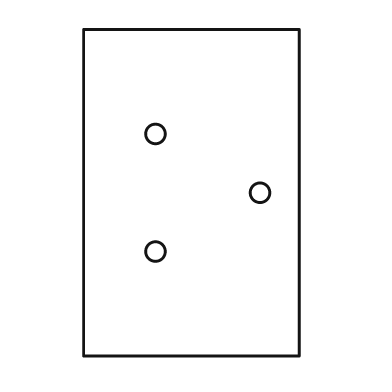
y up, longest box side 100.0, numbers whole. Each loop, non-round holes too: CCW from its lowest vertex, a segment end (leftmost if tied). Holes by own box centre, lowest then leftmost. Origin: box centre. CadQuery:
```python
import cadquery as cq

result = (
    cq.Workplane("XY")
    .moveTo(-33.0, -50.0)
    .lineTo(33.0, -50.0)
    .lineTo(33.0, 50.0)
    .lineTo(-33.0, 50.0)
    .close()
    .moveTo(-11.0, -18.0)
    .circle(3.0)
    .moveTo(21.0, 0.0)
    .circle(3.0)
    .moveTo(-11.0, 18.0)
    .circle(3.0)
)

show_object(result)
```